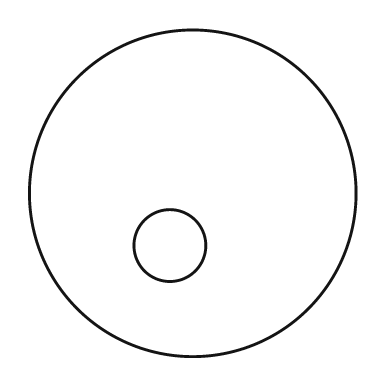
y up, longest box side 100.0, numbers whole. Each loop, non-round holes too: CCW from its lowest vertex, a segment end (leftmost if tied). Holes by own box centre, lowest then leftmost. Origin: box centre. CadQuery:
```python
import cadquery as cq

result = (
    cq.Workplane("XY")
    .moveTo(0.0, 0.0)
    .circle(50.0)
    .moveTo(-7.0, -16.0)
    .circle(11.0)
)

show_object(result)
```